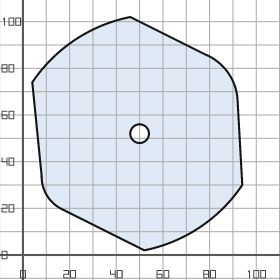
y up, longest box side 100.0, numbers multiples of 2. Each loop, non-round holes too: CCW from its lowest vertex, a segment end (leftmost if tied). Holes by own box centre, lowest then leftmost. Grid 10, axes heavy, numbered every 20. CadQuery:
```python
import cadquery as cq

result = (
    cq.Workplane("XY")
    .moveTo(52.0, 2.0)
    .threePointArc((76.0, 12.0), (94.0, 30.0))
    .lineTo(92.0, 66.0)
    .threePointArc((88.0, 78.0), (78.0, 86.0))
    .lineTo(46.0, 102.0)
    .threePointArc((22.0, 92.0), (4.0, 74.0))
    .lineTo(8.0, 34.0)
    .threePointArc((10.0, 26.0), (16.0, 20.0))
    .close()
    .moveTo(50.0, 52.0)
    .circle(4.0)
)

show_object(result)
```